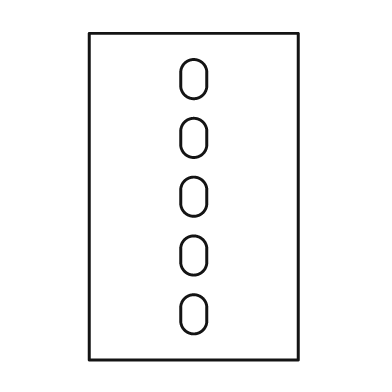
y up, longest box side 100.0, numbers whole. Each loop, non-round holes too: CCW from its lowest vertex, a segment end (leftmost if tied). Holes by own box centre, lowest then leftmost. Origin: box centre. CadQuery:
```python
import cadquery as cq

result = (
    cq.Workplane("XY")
    .moveTo(-32.0, -50.0)
    .lineTo(32.0, -50.0)
    .lineTo(32.0, 50.0)
    .lineTo(-32.0, 50.0)
    .close()
    .moveTo(-4.0, -38.0)
    .threePointArc((0.0, -42.0), (4.0, -38.0))
    .lineTo(4.0, -34.0)
    .threePointArc((0.0, -30.0), (-4.0, -34.0))
    .close()
    .moveTo(-4.0, -20.0)
    .threePointArc((0.0, -24.0), (4.0, -20.0))
    .lineTo(4.0, -16.0)
    .threePointArc((0.0, -12.0), (-4.0, -16.0))
    .close()
    .moveTo(-4.0, -2.0)
    .threePointArc((0.0, -6.0), (4.0, -2.0))
    .lineTo(4.0, 2.0)
    .threePointArc((0.0, 6.0), (-4.0, 2.0))
    .close()
    .moveTo(-4.0, 16.0)
    .threePointArc((0.0, 12.0), (4.0, 16.0))
    .lineTo(4.0, 20.0)
    .threePointArc((0.0, 24.0), (-4.0, 20.0))
    .close()
    .moveTo(-4.0, 34.0)
    .threePointArc((0.0, 30.0), (4.0, 34.0))
    .lineTo(4.0, 38.0)
    .threePointArc((0.0, 42.0), (-4.0, 38.0))
    .close()
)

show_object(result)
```